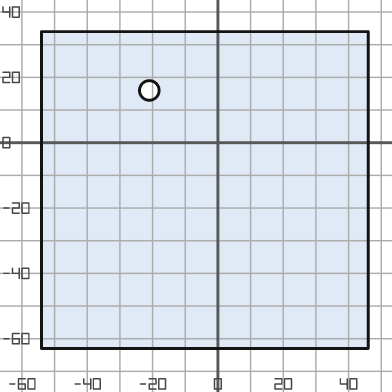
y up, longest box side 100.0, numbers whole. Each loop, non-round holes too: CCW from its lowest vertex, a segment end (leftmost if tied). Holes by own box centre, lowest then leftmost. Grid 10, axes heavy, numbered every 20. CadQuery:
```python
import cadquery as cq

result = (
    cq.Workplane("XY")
    .moveTo(-54.0, -63.0)
    .lineTo(46.0, -63.0)
    .lineTo(46.0, 34.0)
    .lineTo(-54.0, 34.0)
    .close()
    .moveTo(-21.0, 16.0)
    .circle(3.0)
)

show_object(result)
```